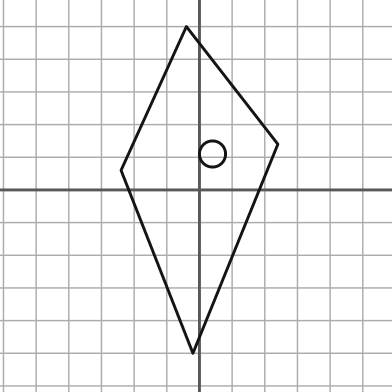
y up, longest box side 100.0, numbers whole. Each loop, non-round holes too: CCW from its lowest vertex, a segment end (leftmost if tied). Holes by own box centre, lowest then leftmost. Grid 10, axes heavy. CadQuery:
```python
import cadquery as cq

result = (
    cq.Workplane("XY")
    .moveTo(-2.0, -50.0)
    .lineTo(24.0, 14.0)
    .lineTo(-4.0, 50.0)
    .lineTo(-24.0, 6.0)
    .close()
    .moveTo(4.0, 11.0)
    .circle(4.0)
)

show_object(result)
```